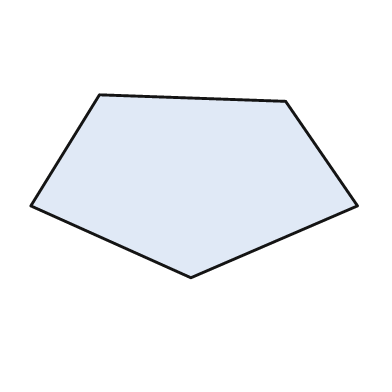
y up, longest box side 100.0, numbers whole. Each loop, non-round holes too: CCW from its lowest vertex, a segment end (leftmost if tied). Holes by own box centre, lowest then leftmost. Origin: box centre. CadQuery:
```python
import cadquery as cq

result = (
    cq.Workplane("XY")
    .moveTo(-1.0, -28.0)
    .lineTo(50.0, -6.0)
    .lineTo(28.0, 26.0)
    .lineTo(-29.0, 28.0)
    .lineTo(-50.0, -6.0)
    .close()
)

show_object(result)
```